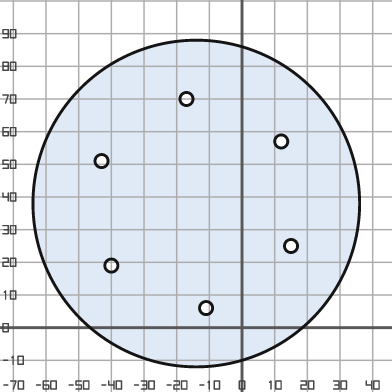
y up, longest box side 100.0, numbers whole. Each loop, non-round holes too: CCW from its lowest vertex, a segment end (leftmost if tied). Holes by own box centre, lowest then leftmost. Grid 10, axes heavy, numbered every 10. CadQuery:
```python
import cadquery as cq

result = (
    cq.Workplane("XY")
    .moveTo(-14.0, 38.0)
    .circle(50.0)
    .moveTo(-11.0, 6.0)
    .circle(2.0)
    .moveTo(-40.0, 19.0)
    .circle(2.0)
    .moveTo(15.0, 25.0)
    .circle(2.0)
    .moveTo(-43.0, 51.0)
    .circle(2.0)
    .moveTo(12.0, 57.0)
    .circle(2.0)
    .moveTo(-17.0, 70.0)
    .circle(2.0)
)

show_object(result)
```